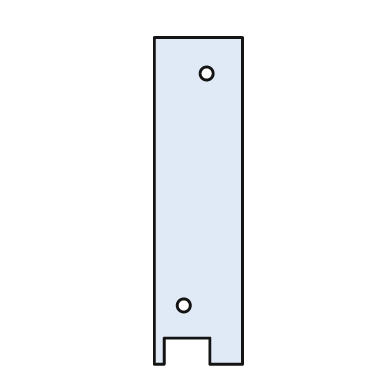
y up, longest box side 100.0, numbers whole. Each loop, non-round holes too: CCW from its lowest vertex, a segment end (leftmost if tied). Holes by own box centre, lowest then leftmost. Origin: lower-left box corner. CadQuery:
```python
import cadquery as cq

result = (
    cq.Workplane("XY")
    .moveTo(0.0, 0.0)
    .lineTo(3.0, 0.0)
    .lineTo(3.0, 8.0)
    .lineTo(17.0, 8.0)
    .lineTo(17.0, 0.0)
    .lineTo(27.0, 0.0)
    .lineTo(27.0, 100.0)
    .lineTo(0.0, 100.0)
    .close()
    .moveTo(9.0, 18.0)
    .circle(2.0)
    .moveTo(16.0, 89.0)
    .circle(2.0)
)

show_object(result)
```